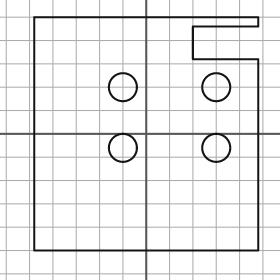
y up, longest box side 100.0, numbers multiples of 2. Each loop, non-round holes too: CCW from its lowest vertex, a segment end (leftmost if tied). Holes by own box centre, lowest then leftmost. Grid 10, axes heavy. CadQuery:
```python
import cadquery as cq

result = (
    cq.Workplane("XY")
    .moveTo(-48.0, -50.0)
    .lineTo(48.0, -50.0)
    .lineTo(48.0, 32.0)
    .lineTo(20.0, 32.0)
    .lineTo(20.0, 46.0)
    .lineTo(48.0, 46.0)
    .lineTo(48.0, 50.0)
    .lineTo(-48.0, 50.0)
    .close()
    .moveTo(-10.0, -6.0)
    .circle(6.0)
    .moveTo(30.0, -6.0)
    .circle(6.0)
    .moveTo(-10.0, 20.0)
    .circle(6.0)
    .moveTo(30.0, 20.0)
    .circle(6.0)
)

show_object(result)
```